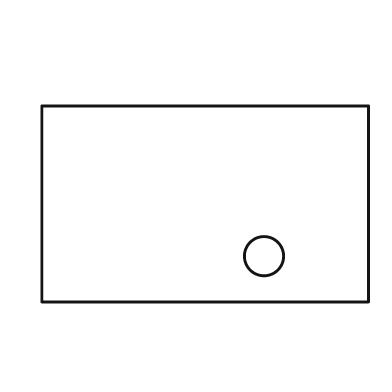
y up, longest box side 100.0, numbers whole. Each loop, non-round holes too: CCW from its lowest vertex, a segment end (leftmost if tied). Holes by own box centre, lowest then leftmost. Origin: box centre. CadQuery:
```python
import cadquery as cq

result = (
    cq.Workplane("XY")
    .moveTo(-50.0, -30.0)
    .lineTo(50.0, -30.0)
    .lineTo(50.0, 30.0)
    .lineTo(-50.0, 30.0)
    .close()
    .moveTo(18.0, -16.0)
    .circle(6.0)
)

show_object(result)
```